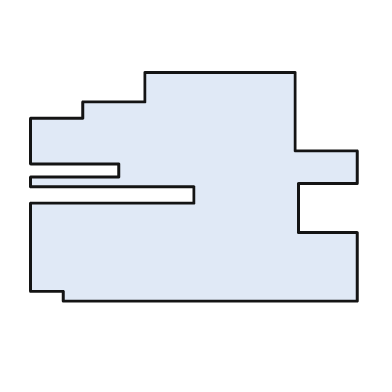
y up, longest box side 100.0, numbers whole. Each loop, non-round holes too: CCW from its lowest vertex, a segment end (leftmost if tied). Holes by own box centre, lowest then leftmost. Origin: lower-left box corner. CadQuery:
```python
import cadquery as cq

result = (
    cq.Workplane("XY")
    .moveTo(10.0, 0.0)
    .lineTo(100.0, 0.0)
    .lineTo(100.0, 21.0)
    .lineTo(82.0, 21.0)
    .lineTo(82.0, 36.0)
    .lineTo(100.0, 36.0)
    .lineTo(100.0, 46.0)
    .lineTo(81.0, 46.0)
    .lineTo(81.0, 70.0)
    .lineTo(35.0, 70.0)
    .lineTo(35.0, 61.0)
    .lineTo(16.0, 61.0)
    .lineTo(16.0, 56.0)
    .lineTo(0.0, 56.0)
    .lineTo(0.0, 42.0)
    .lineTo(27.0, 42.0)
    .lineTo(27.0, 38.0)
    .lineTo(0.0, 38.0)
    .lineTo(0.0, 35.0)
    .lineTo(50.0, 35.0)
    .lineTo(50.0, 30.0)
    .lineTo(0.0, 30.0)
    .lineTo(0.0, 3.0)
    .lineTo(10.0, 3.0)
    .close()
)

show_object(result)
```